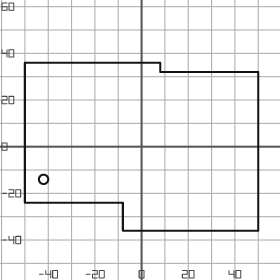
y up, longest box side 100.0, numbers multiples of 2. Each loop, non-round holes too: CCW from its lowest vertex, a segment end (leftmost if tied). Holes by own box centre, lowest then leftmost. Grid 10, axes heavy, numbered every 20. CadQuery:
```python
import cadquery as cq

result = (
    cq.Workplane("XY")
    .moveTo(-8.0, -36.0)
    .lineTo(50.0, -36.0)
    .lineTo(50.0, 32.0)
    .lineTo(8.0, 32.0)
    .lineTo(8.0, 36.0)
    .lineTo(-50.0, 36.0)
    .lineTo(-50.0, -24.0)
    .lineTo(-8.0, -24.0)
    .close()
    .moveTo(-42.0, -14.0)
    .circle(2.0)
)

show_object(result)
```